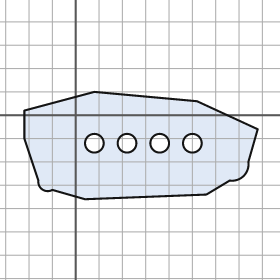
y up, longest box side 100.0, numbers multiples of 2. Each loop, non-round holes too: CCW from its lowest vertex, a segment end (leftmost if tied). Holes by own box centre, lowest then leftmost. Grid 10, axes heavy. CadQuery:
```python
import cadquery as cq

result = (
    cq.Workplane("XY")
    .moveTo(4.0, -36.0)
    .lineTo(56.0, -34.0)
    .lineTo(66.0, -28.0)
    .threePointArc((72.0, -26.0), (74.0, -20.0))
    .lineTo(78.0, -6.0)
    .lineTo(52.0, 6.0)
    .lineTo(8.0, 10.0)
    .lineTo(-22.0, 2.0)
    .lineTo(-22.0, -10.0)
    .lineTo(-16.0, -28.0)
    .threePointArc((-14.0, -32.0), (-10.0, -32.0))
    .close()
    .moveTo(8.0, -12.0)
    .circle(4.0)
    .moveTo(22.0, -12.0)
    .circle(4.0)
    .moveTo(36.0, -12.0)
    .circle(4.0)
    .moveTo(50.0, -12.0)
    .circle(4.0)
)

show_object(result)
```